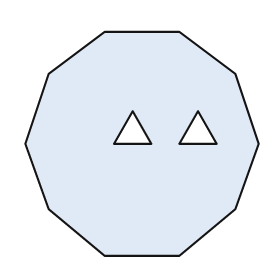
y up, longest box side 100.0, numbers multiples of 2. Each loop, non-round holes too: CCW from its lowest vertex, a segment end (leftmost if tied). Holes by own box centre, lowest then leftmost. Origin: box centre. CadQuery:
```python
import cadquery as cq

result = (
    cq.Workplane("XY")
    .moveTo(-16.0, -48.0)
    .lineTo(16.0, -48.0)
    .lineTo(40.0, -28.0)
    .lineTo(50.0, 0.0)
    .lineTo(40.0, 30.0)
    .lineTo(16.0, 48.0)
    .lineTo(-16.0, 48.0)
    .lineTo(-40.0, 30.0)
    .lineTo(-50.0, 0.0)
    .lineTo(-40.0, -28.0)
    .close()
    .moveTo(-12.0, 0.0)
    .lineTo(4.0, 0.0)
    .lineTo(-4.0, 14.0)
    .close()
    .moveTo(16.0, 0.0)
    .lineTo(32.0, 0.0)
    .lineTo(24.0, 14.0)
    .close()
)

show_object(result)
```